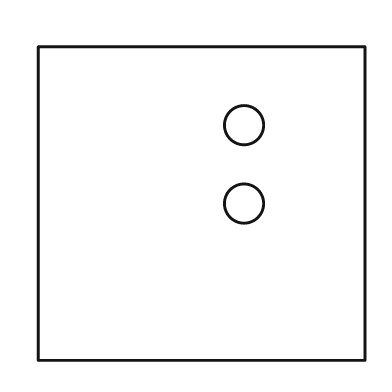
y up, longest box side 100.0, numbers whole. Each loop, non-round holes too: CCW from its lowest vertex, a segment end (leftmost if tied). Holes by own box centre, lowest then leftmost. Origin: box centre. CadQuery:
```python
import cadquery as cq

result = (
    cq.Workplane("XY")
    .moveTo(-50.0, -48.0)
    .lineTo(50.0, -48.0)
    .lineTo(50.0, 48.0)
    .lineTo(-50.0, 48.0)
    .close()
    .moveTo(13.0, 0.0)
    .circle(6.0)
    .moveTo(13.0, 24.0)
    .circle(6.0)
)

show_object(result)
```